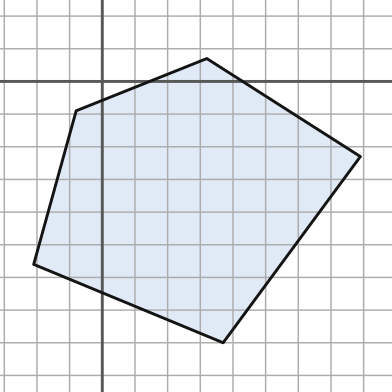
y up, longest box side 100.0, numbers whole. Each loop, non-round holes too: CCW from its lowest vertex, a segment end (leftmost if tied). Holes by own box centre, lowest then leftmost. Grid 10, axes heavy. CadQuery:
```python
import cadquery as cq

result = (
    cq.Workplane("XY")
    .moveTo(37.0, -80.0)
    .lineTo(79.0, -23.0)
    .lineTo(32.0, 7.0)
    .lineTo(-8.0, -9.0)
    .lineTo(-21.0, -56.0)
    .close()
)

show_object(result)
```